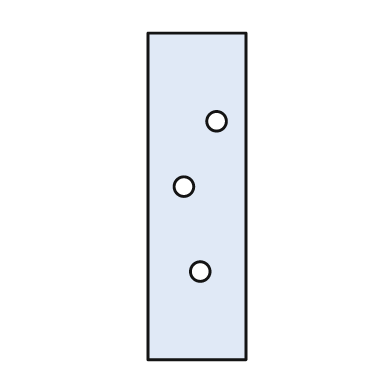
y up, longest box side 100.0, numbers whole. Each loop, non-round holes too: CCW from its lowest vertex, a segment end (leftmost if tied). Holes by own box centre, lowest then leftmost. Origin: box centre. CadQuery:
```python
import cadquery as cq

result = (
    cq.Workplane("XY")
    .moveTo(-15.0, -50.0)
    .lineTo(15.0, -50.0)
    .lineTo(15.0, 50.0)
    .lineTo(-15.0, 50.0)
    .close()
    .moveTo(1.0, -23.0)
    .circle(3.0)
    .moveTo(-4.0, 3.0)
    .circle(3.0)
    .moveTo(6.0, 23.0)
    .circle(3.0)
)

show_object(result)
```